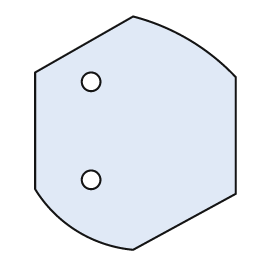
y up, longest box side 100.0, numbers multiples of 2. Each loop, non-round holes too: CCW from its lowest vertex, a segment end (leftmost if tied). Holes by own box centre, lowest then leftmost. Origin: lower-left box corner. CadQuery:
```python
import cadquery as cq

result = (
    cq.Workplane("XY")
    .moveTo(42.0, 0.0)
    .lineTo(86.0, 24.0)
    .lineTo(86.0, 74.0)
    .threePointArc((66.0, 90.0), (42.0, 100.0))
    .lineTo(0.0, 76.0)
    .lineTo(0.0, 26.0)
    .threePointArc((18.0, 8.0), (42.0, 0.0))
    .close()
    .moveTo(24.0, 30.0)
    .circle(4.0)
    .moveTo(24.0, 72.0)
    .circle(4.0)
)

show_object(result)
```